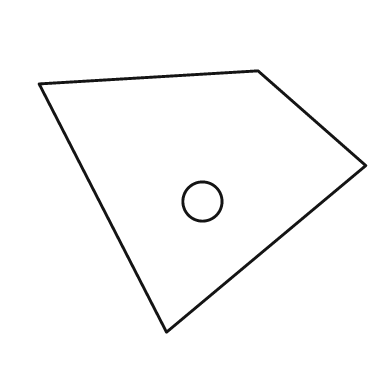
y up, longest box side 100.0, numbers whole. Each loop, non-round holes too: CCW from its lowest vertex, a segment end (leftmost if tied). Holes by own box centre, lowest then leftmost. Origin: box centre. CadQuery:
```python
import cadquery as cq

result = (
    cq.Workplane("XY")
    .moveTo(-11.0, -40.0)
    .lineTo(50.0, 11.0)
    .lineTo(17.0, 40.0)
    .lineTo(-50.0, 36.0)
    .close()
    .moveTo(0.0, 0.0)
    .circle(6.0)
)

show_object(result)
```